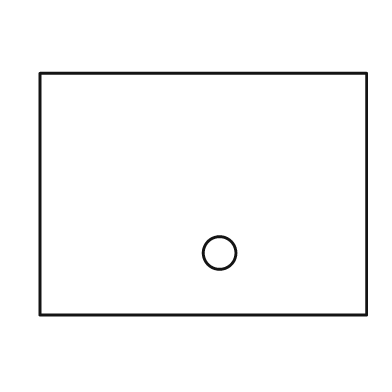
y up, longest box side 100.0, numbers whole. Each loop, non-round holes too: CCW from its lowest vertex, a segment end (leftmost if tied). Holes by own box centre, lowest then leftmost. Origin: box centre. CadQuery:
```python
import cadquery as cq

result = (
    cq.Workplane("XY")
    .moveTo(-50.0, -37.0)
    .lineTo(50.0, -37.0)
    .lineTo(50.0, 37.0)
    .lineTo(-50.0, 37.0)
    .close()
    .moveTo(5.0, -18.0)
    .circle(5.0)
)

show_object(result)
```